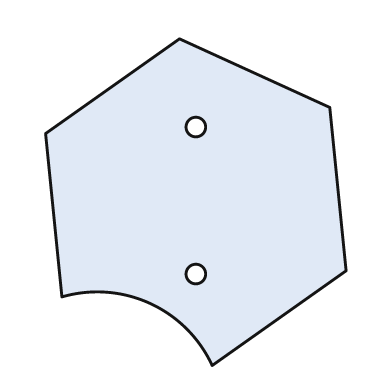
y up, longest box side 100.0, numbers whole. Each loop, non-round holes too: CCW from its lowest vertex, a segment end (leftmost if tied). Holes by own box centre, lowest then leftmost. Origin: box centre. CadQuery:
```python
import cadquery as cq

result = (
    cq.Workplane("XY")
    .moveTo(5.0, -50.0)
    .lineTo(46.0, -21.0)
    .lineTo(41.0, 29.0)
    .lineTo(-5.0, 50.0)
    .lineTo(-46.0, 21.0)
    .lineTo(-41.0, -29.0)
    .threePointArc((-14.0, -31.0), (5.0, -50.0))
    .close()
    .moveTo(0.0, -22.0)
    .circle(3.0)
    .moveTo(0.0, 23.0)
    .circle(3.0)
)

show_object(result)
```